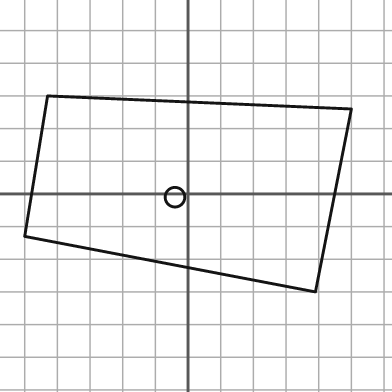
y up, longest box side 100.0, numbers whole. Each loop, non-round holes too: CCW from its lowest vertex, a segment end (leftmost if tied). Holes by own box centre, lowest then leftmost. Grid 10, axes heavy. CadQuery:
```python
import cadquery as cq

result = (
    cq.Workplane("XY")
    .moveTo(39.0, -30.0)
    .lineTo(50.0, 26.0)
    .lineTo(-43.0, 30.0)
    .lineTo(-50.0, -13.0)
    .close()
    .moveTo(-4.0, -1.0)
    .circle(3.0)
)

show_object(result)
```